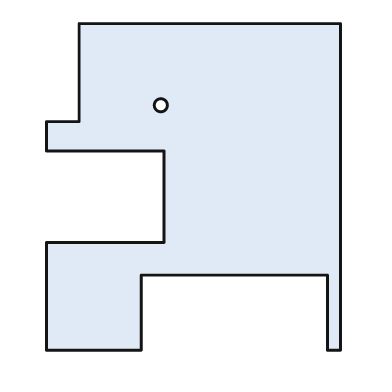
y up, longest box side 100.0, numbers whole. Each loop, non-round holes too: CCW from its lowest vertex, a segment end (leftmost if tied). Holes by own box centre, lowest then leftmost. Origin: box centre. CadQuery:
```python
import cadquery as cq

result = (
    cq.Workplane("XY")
    .moveTo(-45.0, -50.0)
    .lineTo(-16.0, -50.0)
    .lineTo(-16.0, -27.0)
    .lineTo(41.0, -27.0)
    .lineTo(41.0, -50.0)
    .lineTo(45.0, -50.0)
    .lineTo(45.0, 50.0)
    .lineTo(-35.0, 50.0)
    .lineTo(-35.0, 20.0)
    .lineTo(-45.0, 20.0)
    .lineTo(-45.0, 11.0)
    .lineTo(-9.0, 11.0)
    .lineTo(-9.0, -17.0)
    .lineTo(-45.0, -17.0)
    .close()
    .moveTo(-10.0, 25.0)
    .circle(2.0)
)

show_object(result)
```